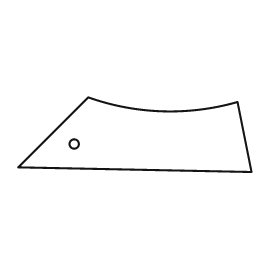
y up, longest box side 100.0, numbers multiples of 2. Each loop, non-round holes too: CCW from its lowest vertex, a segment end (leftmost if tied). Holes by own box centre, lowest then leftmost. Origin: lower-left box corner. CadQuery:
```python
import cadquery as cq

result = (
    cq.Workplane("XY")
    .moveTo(100.0, 0.0)
    .lineTo(94.0, 30.0)
    .threePointArc((62.0, 26.0), (30.0, 32.0))
    .lineTo(0.0, 2.0)
    .close()
    .moveTo(24.0, 12.0)
    .circle(2.0)
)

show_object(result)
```